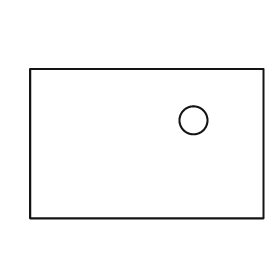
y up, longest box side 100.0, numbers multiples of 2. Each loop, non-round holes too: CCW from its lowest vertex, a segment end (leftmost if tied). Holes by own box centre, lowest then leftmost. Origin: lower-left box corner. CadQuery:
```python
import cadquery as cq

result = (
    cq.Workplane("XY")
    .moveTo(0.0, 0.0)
    .lineTo(100.0, 0.0)
    .lineTo(100.0, 64.0)
    .lineTo(0.0, 64.0)
    .close()
    .moveTo(70.0, 42.0)
    .circle(6.0)
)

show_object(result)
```